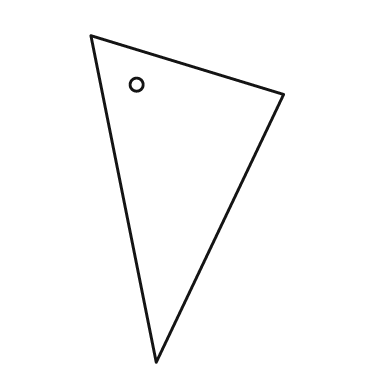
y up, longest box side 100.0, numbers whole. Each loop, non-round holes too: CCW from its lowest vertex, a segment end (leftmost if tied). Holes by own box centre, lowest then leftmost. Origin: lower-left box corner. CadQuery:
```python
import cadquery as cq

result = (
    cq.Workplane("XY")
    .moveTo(20.0, 0.0)
    .lineTo(59.0, 82.0)
    .lineTo(0.0, 100.0)
    .close()
    .moveTo(14.0, 85.0)
    .circle(2.0)
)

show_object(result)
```